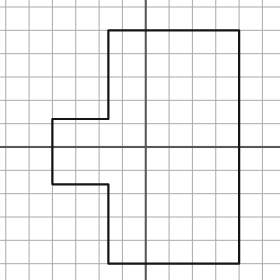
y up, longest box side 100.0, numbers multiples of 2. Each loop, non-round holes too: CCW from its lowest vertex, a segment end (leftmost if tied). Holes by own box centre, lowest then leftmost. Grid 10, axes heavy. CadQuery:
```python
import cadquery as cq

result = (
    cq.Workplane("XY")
    .moveTo(-16.0, -50.0)
    .lineTo(40.0, -50.0)
    .lineTo(40.0, 50.0)
    .lineTo(-16.0, 50.0)
    .lineTo(-16.0, 12.0)
    .lineTo(-40.0, 12.0)
    .lineTo(-40.0, -16.0)
    .lineTo(-16.0, -16.0)
    .close()
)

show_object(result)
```